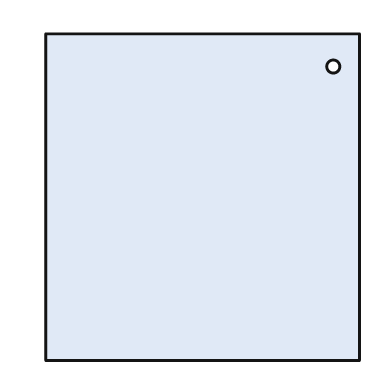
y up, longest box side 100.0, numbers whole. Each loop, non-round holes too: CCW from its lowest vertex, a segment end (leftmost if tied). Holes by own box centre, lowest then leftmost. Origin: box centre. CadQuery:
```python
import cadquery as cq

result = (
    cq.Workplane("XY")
    .moveTo(-48.0, -50.0)
    .lineTo(48.0, -50.0)
    .lineTo(48.0, 50.0)
    .lineTo(-48.0, 50.0)
    .close()
    .moveTo(40.0, 40.0)
    .circle(2.0)
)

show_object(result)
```